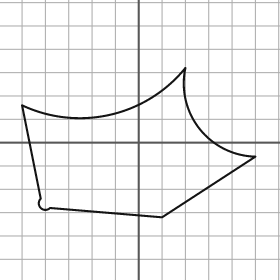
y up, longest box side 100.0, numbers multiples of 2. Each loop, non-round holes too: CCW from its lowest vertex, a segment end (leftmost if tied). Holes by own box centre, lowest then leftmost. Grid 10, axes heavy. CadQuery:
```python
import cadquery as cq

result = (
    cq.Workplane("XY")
    .moveTo(10.0, -32.0)
    .lineTo(50.0, -6.0)
    .threePointArc((26.0, 6.0), (20.0, 32.0))
    .threePointArc((-12.0, 12.0), (-50.0, 16.0))
    .lineTo(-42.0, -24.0)
    .threePointArc((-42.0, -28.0), (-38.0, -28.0))
    .close()
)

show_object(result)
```